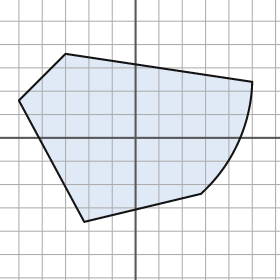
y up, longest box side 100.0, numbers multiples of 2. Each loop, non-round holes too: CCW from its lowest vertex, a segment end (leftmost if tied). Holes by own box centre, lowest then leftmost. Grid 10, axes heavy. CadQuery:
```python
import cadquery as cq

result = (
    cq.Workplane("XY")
    .moveTo(-22.0, -36.0)
    .lineTo(28.0, -24.0)
    .threePointArc((44.0, -2.0), (50.0, 24.0))
    .lineTo(-30.0, 36.0)
    .lineTo(-50.0, 16.0)
    .close()
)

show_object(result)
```